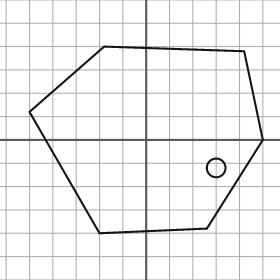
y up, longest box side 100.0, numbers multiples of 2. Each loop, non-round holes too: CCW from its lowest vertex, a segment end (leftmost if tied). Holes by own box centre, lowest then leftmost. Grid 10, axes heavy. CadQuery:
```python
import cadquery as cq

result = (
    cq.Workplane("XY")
    .moveTo(-20.0, -40.0)
    .lineTo(26.0, -38.0)
    .lineTo(50.0, 0.0)
    .lineTo(42.0, 38.0)
    .lineTo(-18.0, 40.0)
    .lineTo(-50.0, 12.0)
    .close()
    .moveTo(30.0, -12.0)
    .circle(4.0)
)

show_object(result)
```